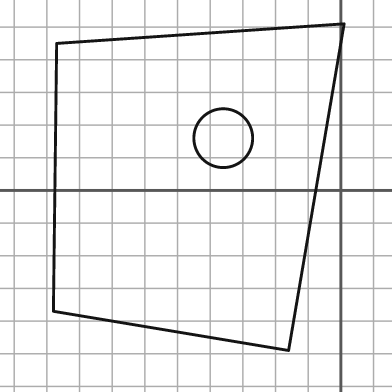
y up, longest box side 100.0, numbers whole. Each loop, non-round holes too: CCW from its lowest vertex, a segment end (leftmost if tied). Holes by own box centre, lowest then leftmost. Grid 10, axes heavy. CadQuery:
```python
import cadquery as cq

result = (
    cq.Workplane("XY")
    .moveTo(-16.0, -49.0)
    .lineTo(1.0, 51.0)
    .lineTo(-87.0, 45.0)
    .lineTo(-88.0, -37.0)
    .close()
    .moveTo(-36.0, 16.0)
    .circle(9.0)
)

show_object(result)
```